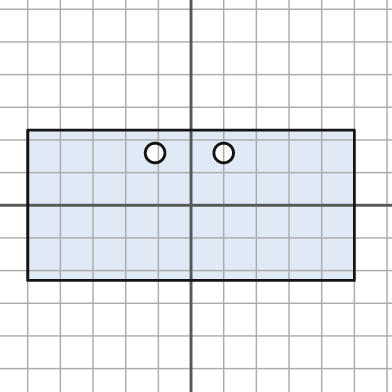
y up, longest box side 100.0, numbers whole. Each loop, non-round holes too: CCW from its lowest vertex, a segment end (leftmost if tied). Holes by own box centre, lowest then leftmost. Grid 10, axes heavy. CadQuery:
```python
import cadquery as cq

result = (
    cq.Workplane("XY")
    .moveTo(-50.0, -23.0)
    .lineTo(50.0, -23.0)
    .lineTo(50.0, 23.0)
    .lineTo(-50.0, 23.0)
    .close()
    .moveTo(-11.0, 16.0)
    .circle(3.0)
    .moveTo(10.0, 16.0)
    .circle(3.0)
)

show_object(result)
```